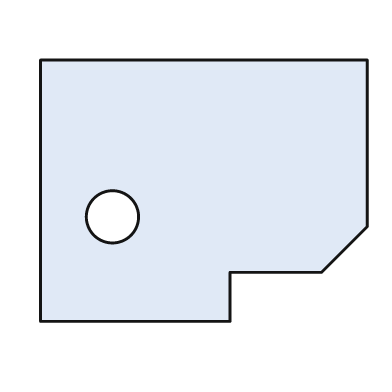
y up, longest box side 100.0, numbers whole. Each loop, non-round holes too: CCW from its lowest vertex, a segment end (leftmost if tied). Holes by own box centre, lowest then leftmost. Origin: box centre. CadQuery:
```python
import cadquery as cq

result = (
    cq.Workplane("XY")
    .moveTo(-50.0, -40.0)
    .lineTo(8.0, -40.0)
    .lineTo(8.0, -25.0)
    .lineTo(36.0, -25.0)
    .lineTo(50.0, -11.0)
    .lineTo(50.0, 40.0)
    .lineTo(-50.0, 40.0)
    .close()
    .moveTo(-28.0, -8.0)
    .circle(8.0)
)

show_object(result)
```